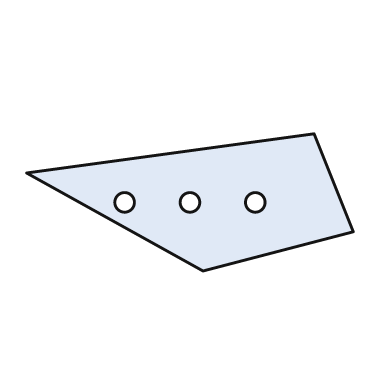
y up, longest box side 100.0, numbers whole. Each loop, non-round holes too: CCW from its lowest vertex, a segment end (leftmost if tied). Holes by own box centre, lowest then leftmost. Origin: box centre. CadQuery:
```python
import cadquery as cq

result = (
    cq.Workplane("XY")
    .moveTo(4.0, -21.0)
    .lineTo(50.0, -9.0)
    .lineTo(38.0, 21.0)
    .lineTo(-50.0, 9.0)
    .close()
    .moveTo(-20.0, 0.0)
    .circle(3.0)
    .moveTo(0.0, 0.0)
    .circle(3.0)
    .moveTo(20.0, 0.0)
    .circle(3.0)
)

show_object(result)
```